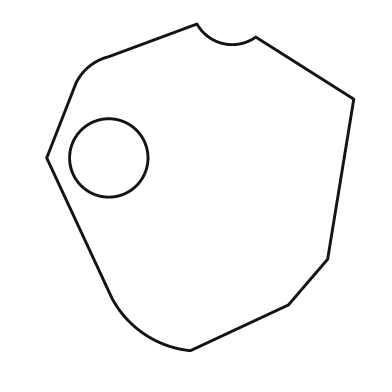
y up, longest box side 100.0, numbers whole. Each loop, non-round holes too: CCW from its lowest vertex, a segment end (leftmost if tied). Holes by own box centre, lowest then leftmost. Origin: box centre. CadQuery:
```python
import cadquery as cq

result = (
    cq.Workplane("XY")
    .moveTo(-3.0, -50.0)
    .lineTo(27.0, -36.0)
    .lineTo(39.0, -22.0)
    .lineTo(47.0, 27.0)
    .lineTo(17.0, 46.0)
    .threePointArc((7.0, 44.0), (-1.0, 50.0))
    .lineTo(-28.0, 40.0)
    .threePointArc((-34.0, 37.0), (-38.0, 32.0))
    .lineTo(-47.0, 9.0)
    .lineTo(-27.0, -34.0)
    .threePointArc((-17.0, -45.0), (-3.0, -50.0))
    .close()
    .moveTo(-28.0, 9.0)
    .circle(12.0)
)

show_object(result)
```